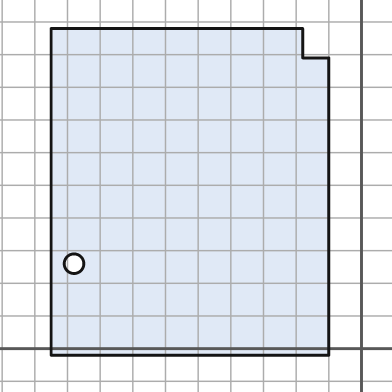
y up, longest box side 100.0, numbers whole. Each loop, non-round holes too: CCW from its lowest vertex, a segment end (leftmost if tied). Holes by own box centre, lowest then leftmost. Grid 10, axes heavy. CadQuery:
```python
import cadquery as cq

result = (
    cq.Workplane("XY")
    .moveTo(-95.0, -2.0)
    .lineTo(-10.0, -2.0)
    .lineTo(-10.0, 89.0)
    .lineTo(-18.0, 89.0)
    .lineTo(-18.0, 98.0)
    .lineTo(-95.0, 98.0)
    .close()
    .moveTo(-88.0, 26.0)
    .circle(3.0)
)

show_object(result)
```